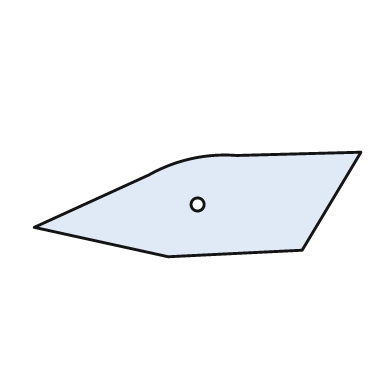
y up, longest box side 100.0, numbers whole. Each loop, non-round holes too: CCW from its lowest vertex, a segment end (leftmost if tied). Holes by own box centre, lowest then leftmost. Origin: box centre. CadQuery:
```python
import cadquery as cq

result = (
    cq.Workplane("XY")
    .moveTo(-9.0, -16.0)
    .lineTo(32.0, -14.0)
    .lineTo(50.0, 16.0)
    .lineTo(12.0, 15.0)
    .threePointArc((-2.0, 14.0), (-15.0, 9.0))
    .lineTo(-50.0, -7.0)
    .close()
    .moveTo(0.0, 0.0)
    .circle(2.0)
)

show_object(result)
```